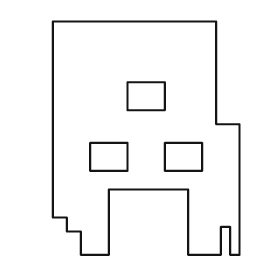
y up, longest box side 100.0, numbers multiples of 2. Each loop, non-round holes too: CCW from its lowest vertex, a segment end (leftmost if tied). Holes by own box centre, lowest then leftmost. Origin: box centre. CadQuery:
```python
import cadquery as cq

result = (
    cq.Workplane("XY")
    .moveTo(-28.0, -50.0)
    .lineTo(-16.0, -50.0)
    .lineTo(-16.0, -22.0)
    .lineTo(18.0, -22.0)
    .lineTo(18.0, -50.0)
    .lineTo(32.0, -50.0)
    .lineTo(32.0, -38.0)
    .lineTo(36.0, -38.0)
    .lineTo(36.0, -50.0)
    .lineTo(40.0, -50.0)
    .lineTo(40.0, 6.0)
    .lineTo(30.0, 6.0)
    .lineTo(30.0, 50.0)
    .lineTo(-40.0, 50.0)
    .lineTo(-40.0, -34.0)
    .lineTo(-34.0, -34.0)
    .lineTo(-34.0, -40.0)
    .lineTo(-28.0, -40.0)
    .close()
    .moveTo(-24.0, -14.0)
    .lineTo(-8.0, -14.0)
    .lineTo(-8.0, -2.0)
    .lineTo(-24.0, -2.0)
    .close()
    .moveTo(8.0, -14.0)
    .lineTo(24.0, -14.0)
    .lineTo(24.0, -2.0)
    .lineTo(8.0, -2.0)
    .close()
    .moveTo(-8.0, 12.0)
    .lineTo(8.0, 12.0)
    .lineTo(8.0, 24.0)
    .lineTo(-8.0, 24.0)
    .close()
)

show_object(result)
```